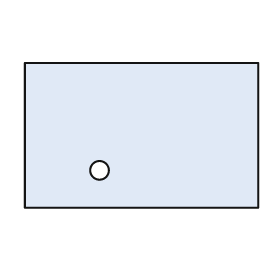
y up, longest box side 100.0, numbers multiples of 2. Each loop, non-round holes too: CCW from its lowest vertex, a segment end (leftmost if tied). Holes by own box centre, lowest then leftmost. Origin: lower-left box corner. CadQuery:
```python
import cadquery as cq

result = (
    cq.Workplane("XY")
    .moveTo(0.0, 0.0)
    .lineTo(100.0, 0.0)
    .lineTo(100.0, 62.0)
    .lineTo(0.0, 62.0)
    .close()
    .moveTo(32.0, 16.0)
    .circle(4.0)
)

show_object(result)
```